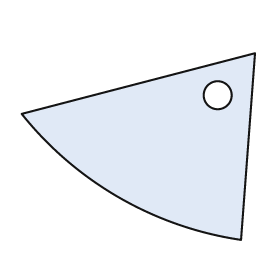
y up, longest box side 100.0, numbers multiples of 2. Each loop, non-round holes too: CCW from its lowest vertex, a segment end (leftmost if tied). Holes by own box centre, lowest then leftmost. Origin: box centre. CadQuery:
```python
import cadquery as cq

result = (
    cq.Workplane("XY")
    .moveTo(44.0, -40.0)
    .lineTo(50.0, 40.0)
    .lineTo(-50.0, 14.0)
    .threePointArc((-8.0, -22.0), (44.0, -40.0))
    .close()
    .moveTo(34.0, 22.0)
    .circle(6.0)
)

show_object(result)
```